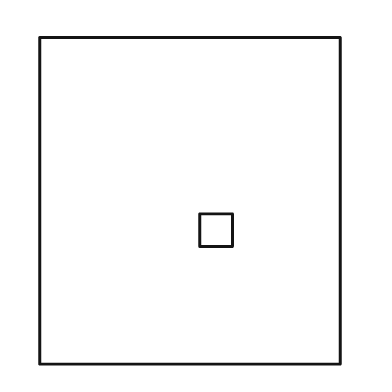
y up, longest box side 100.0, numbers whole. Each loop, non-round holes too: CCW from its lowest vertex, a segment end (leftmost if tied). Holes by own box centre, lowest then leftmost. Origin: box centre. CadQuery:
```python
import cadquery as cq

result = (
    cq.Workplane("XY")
    .moveTo(-46.0, -50.0)
    .lineTo(46.0, -50.0)
    .lineTo(46.0, 50.0)
    .lineTo(-46.0, 50.0)
    .close()
    .moveTo(3.0, -14.0)
    .lineTo(13.0, -14.0)
    .lineTo(13.0, -4.0)
    .lineTo(3.0, -4.0)
    .close()
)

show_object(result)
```